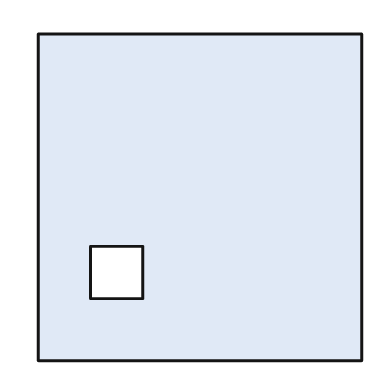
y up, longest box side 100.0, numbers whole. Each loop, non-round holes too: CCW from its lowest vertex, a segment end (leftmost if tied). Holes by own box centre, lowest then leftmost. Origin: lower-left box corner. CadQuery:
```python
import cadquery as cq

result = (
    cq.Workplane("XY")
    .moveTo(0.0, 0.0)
    .lineTo(99.0, 0.0)
    .lineTo(99.0, 100.0)
    .lineTo(0.0, 100.0)
    .close()
    .moveTo(16.0, 19.0)
    .lineTo(32.0, 19.0)
    .lineTo(32.0, 35.0)
    .lineTo(16.0, 35.0)
    .close()
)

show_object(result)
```